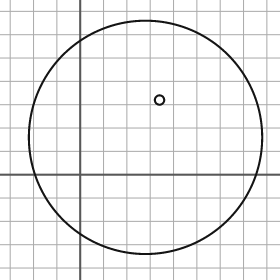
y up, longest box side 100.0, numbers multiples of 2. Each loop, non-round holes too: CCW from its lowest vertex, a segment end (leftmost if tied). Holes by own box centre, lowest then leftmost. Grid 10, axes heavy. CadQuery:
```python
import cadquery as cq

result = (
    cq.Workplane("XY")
    .moveTo(28.0, 16.0)
    .circle(50.0)
    .moveTo(34.0, 32.0)
    .circle(2.0)
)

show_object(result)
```